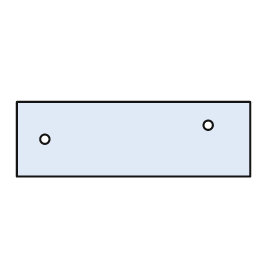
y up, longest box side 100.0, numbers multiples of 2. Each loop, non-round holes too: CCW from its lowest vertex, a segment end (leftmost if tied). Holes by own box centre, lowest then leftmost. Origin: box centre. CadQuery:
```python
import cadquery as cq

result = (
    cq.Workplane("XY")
    .moveTo(-50.0, -16.0)
    .lineTo(50.0, -16.0)
    .lineTo(50.0, 16.0)
    .lineTo(-50.0, 16.0)
    .close()
    .moveTo(-38.0, 0.0)
    .circle(2.0)
    .moveTo(32.0, 6.0)
    .circle(2.0)
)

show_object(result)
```